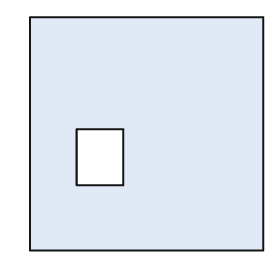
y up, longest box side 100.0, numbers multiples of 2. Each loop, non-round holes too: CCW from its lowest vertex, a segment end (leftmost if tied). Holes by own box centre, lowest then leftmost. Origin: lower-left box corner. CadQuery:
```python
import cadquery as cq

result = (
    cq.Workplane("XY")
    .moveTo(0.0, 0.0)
    .lineTo(100.0, 0.0)
    .lineTo(100.0, 100.0)
    .lineTo(0.0, 100.0)
    .close()
    .moveTo(20.0, 28.0)
    .lineTo(40.0, 28.0)
    .lineTo(40.0, 52.0)
    .lineTo(20.0, 52.0)
    .close()
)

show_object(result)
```